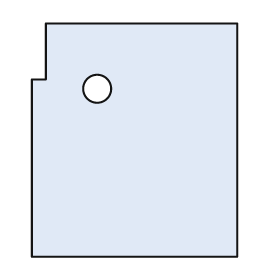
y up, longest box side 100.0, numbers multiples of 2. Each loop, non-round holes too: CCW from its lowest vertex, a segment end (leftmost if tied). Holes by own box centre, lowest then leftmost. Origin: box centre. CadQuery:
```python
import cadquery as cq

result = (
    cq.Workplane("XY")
    .moveTo(-44.0, -50.0)
    .lineTo(44.0, -50.0)
    .lineTo(44.0, 50.0)
    .lineTo(-38.0, 50.0)
    .lineTo(-38.0, 26.0)
    .lineTo(-44.0, 26.0)
    .close()
    .moveTo(-16.0, 22.0)
    .circle(6.0)
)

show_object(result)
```